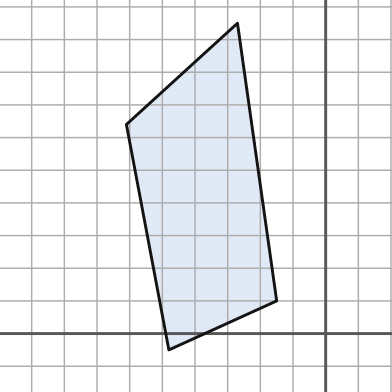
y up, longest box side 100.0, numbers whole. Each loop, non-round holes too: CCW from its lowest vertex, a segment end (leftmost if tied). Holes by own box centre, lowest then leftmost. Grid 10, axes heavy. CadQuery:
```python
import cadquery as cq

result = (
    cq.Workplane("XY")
    .moveTo(-48.0, -5.0)
    .lineTo(-15.0, 10.0)
    .lineTo(-27.0, 95.0)
    .lineTo(-61.0, 64.0)
    .close()
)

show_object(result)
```